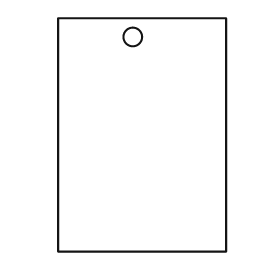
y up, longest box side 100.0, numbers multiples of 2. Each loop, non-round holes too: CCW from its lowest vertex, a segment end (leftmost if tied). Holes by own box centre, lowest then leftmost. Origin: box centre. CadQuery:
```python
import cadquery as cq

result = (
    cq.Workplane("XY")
    .moveTo(-36.0, -50.0)
    .lineTo(36.0, -50.0)
    .lineTo(36.0, 50.0)
    .lineTo(-36.0, 50.0)
    .close()
    .moveTo(-4.0, 42.0)
    .circle(4.0)
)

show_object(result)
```